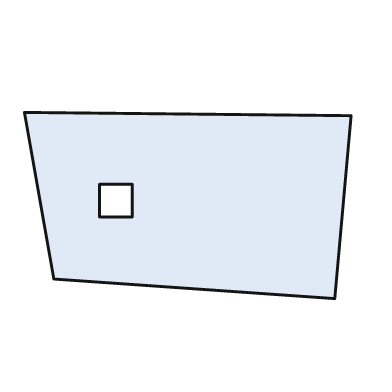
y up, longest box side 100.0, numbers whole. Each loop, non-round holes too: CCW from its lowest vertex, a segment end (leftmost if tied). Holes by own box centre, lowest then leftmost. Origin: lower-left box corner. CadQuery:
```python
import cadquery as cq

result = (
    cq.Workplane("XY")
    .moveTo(95.0, 0.0)
    .lineTo(100.0, 56.0)
    .lineTo(0.0, 57.0)
    .lineTo(9.0, 6.0)
    .close()
    .moveTo(23.0, 25.0)
    .lineTo(33.0, 25.0)
    .lineTo(33.0, 35.0)
    .lineTo(23.0, 35.0)
    .close()
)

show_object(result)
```